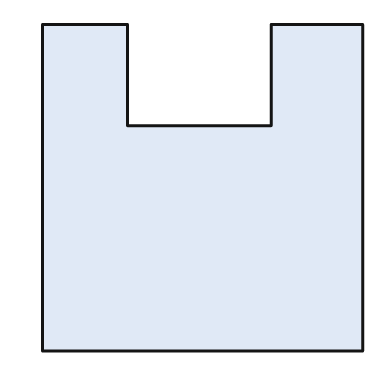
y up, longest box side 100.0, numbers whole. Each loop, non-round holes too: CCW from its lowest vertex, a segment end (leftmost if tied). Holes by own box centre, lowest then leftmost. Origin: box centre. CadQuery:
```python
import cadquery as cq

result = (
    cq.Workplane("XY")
    .moveTo(-49.0, -50.0)
    .lineTo(49.0, -50.0)
    .lineTo(49.0, 50.0)
    .lineTo(21.0, 50.0)
    .lineTo(21.0, 19.0)
    .lineTo(-23.0, 19.0)
    .lineTo(-23.0, 50.0)
    .lineTo(-49.0, 50.0)
    .close()
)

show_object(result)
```